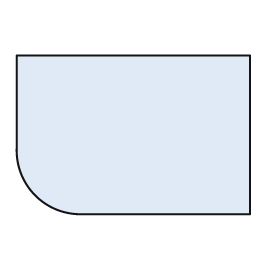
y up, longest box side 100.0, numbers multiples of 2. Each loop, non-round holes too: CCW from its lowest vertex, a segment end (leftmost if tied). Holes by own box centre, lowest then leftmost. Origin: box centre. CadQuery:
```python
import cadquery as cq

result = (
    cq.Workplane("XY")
    .moveTo(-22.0, -34.0)
    .lineTo(50.0, -34.0)
    .lineTo(50.0, 34.0)
    .lineTo(-50.0, 34.0)
    .lineTo(-50.0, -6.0)
    .threePointArc((-42.0, -26.0), (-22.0, -34.0))
    .close()
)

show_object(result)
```